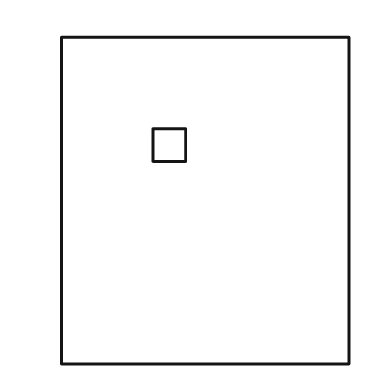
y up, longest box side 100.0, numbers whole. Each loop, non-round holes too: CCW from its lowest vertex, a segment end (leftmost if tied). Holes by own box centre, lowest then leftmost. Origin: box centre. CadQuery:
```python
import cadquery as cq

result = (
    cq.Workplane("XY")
    .moveTo(-44.0, -50.0)
    .lineTo(44.0, -50.0)
    .lineTo(44.0, 50.0)
    .lineTo(-44.0, 50.0)
    .close()
    .moveTo(-16.0, 12.0)
    .lineTo(-6.0, 12.0)
    .lineTo(-6.0, 22.0)
    .lineTo(-16.0, 22.0)
    .close()
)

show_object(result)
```